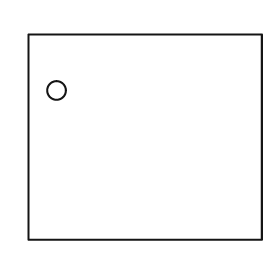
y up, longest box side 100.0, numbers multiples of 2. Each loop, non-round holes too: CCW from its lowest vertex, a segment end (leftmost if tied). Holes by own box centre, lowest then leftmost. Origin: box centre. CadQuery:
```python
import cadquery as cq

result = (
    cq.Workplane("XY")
    .moveTo(-50.0, -44.0)
    .lineTo(50.0, -44.0)
    .lineTo(50.0, 44.0)
    .lineTo(-50.0, 44.0)
    .close()
    .moveTo(-38.0, 20.0)
    .circle(4.0)
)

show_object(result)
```